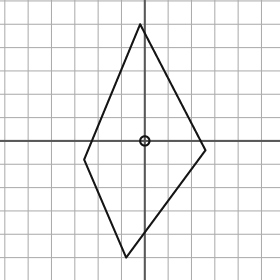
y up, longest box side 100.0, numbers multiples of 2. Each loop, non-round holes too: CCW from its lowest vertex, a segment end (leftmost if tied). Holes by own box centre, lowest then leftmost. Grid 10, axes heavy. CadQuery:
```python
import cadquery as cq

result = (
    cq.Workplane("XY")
    .moveTo(-8.0, -50.0)
    .lineTo(26.0, -4.0)
    .lineTo(-2.0, 50.0)
    .lineTo(-26.0, -8.0)
    .close()
    .moveTo(0.0, 0.0)
    .circle(2.0)
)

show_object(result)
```